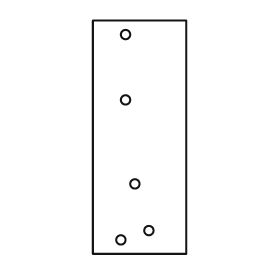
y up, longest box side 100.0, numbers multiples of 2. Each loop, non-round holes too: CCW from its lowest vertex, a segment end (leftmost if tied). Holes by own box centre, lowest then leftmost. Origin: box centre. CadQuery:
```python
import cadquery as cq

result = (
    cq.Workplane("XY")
    .moveTo(-20.0, -50.0)
    .lineTo(20.0, -50.0)
    .lineTo(20.0, 50.0)
    .lineTo(-20.0, 50.0)
    .close()
    .moveTo(-8.0, -44.0)
    .circle(2.0)
    .moveTo(4.0, -40.0)
    .circle(2.0)
    .moveTo(-2.0, -20.0)
    .circle(2.0)
    .moveTo(-6.0, 16.0)
    .circle(2.0)
    .moveTo(-6.0, 44.0)
    .circle(2.0)
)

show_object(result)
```